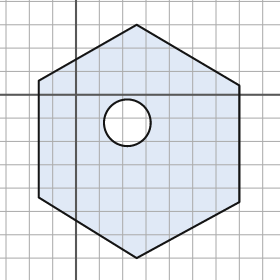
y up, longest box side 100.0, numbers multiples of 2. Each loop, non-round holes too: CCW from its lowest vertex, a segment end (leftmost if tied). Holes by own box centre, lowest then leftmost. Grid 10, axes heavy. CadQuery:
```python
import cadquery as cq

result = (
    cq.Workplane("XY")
    .moveTo(26.0, -70.0)
    .lineTo(70.0, -46.0)
    .lineTo(70.0, 4.0)
    .lineTo(26.0, 30.0)
    .lineTo(-16.0, 6.0)
    .lineTo(-16.0, -44.0)
    .close()
    .moveTo(22.0, -12.0)
    .circle(10.0)
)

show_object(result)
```